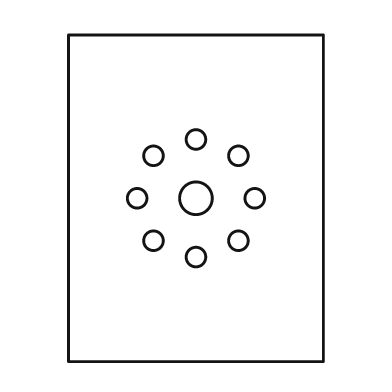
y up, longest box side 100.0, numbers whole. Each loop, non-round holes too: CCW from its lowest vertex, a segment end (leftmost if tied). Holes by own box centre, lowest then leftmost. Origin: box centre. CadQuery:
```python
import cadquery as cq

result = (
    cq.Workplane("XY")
    .moveTo(-39.0, -50.0)
    .lineTo(39.0, -50.0)
    .lineTo(39.0, 50.0)
    .lineTo(-39.0, 50.0)
    .close()
    .moveTo(0.0, -18.0)
    .circle(3.0)
    .moveTo(-13.0, -13.0)
    .circle(3.0)
    .moveTo(13.0, -13.0)
    .circle(3.0)
    .moveTo(-18.0, 0.0)
    .circle(3.0)
    .moveTo(0.0, 0.0)
    .circle(5.0)
    .moveTo(18.0, 0.0)
    .circle(3.0)
    .moveTo(-13.0, 13.0)
    .circle(3.0)
    .moveTo(13.0, 13.0)
    .circle(3.0)
    .moveTo(0.0, 18.0)
    .circle(3.0)
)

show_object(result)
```